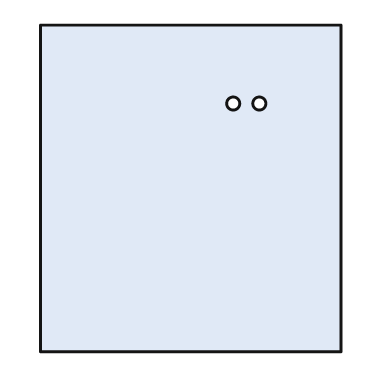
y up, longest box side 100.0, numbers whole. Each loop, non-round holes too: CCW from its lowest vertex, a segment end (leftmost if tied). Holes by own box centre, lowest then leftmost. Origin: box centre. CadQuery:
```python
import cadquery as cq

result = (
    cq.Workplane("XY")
    .moveTo(-46.0, -50.0)
    .lineTo(46.0, -50.0)
    .lineTo(46.0, 50.0)
    .lineTo(-46.0, 50.0)
    .close()
    .moveTo(13.0, 26.0)
    .circle(2.0)
    .moveTo(21.0, 26.0)
    .circle(2.0)
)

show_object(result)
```